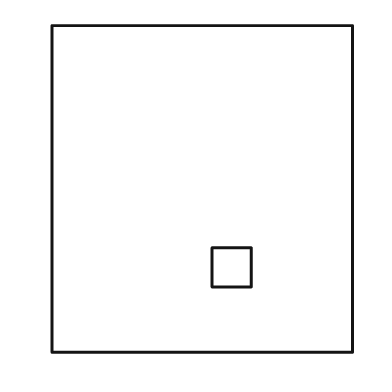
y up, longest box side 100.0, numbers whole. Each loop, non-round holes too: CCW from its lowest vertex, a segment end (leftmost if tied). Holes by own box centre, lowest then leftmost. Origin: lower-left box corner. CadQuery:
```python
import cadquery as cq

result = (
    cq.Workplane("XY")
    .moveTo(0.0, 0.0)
    .lineTo(92.0, 0.0)
    .lineTo(92.0, 100.0)
    .lineTo(0.0, 100.0)
    .close()
    .moveTo(49.0, 20.0)
    .lineTo(61.0, 20.0)
    .lineTo(61.0, 32.0)
    .lineTo(49.0, 32.0)
    .close()
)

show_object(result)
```